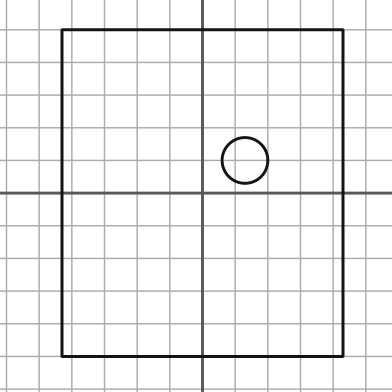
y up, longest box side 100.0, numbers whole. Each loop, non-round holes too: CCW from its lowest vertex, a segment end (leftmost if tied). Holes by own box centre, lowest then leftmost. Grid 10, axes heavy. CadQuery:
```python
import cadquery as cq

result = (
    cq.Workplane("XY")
    .moveTo(-43.0, -50.0)
    .lineTo(43.0, -50.0)
    .lineTo(43.0, 50.0)
    .lineTo(-43.0, 50.0)
    .close()
    .moveTo(13.0, 10.0)
    .circle(7.0)
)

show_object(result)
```